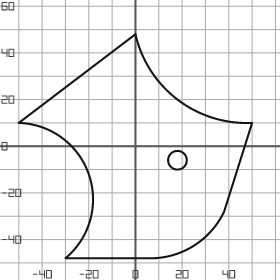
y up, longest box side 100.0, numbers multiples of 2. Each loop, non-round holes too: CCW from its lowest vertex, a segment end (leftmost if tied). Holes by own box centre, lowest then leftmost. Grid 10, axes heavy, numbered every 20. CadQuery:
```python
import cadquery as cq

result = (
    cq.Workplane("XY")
    .moveTo(-30.0, -48.0)
    .lineTo(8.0, -48.0)
    .threePointArc((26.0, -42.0), (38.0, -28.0))
    .lineTo(50.0, 10.0)
    .threePointArc((18.0, 20.0), (0.0, 48.0))
    .lineTo(-50.0, 10.0)
    .threePointArc((-20.0, -12.0), (-30.0, -48.0))
    .close()
    .moveTo(18.0, -6.0)
    .circle(4.0)
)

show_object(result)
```